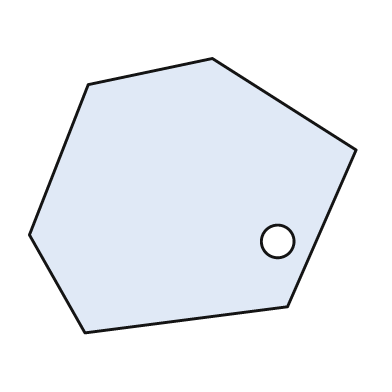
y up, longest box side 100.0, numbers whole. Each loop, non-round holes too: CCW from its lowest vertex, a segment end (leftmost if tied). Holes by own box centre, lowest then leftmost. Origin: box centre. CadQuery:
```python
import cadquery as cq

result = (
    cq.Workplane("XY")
    .moveTo(-33.0, -42.0)
    .lineTo(29.0, -34.0)
    .lineTo(50.0, 14.0)
    .lineTo(6.0, 42.0)
    .lineTo(-32.0, 34.0)
    .lineTo(-50.0, -12.0)
    .close()
    .moveTo(26.0, -14.0)
    .circle(5.0)
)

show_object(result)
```